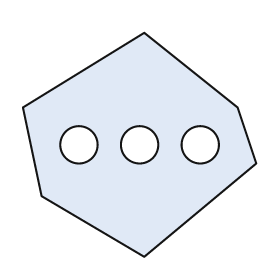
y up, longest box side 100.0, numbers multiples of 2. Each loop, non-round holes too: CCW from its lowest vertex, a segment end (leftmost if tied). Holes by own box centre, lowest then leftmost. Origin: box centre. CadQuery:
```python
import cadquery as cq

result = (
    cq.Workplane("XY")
    .moveTo(2.0, -48.0)
    .lineTo(50.0, -8.0)
    .lineTo(42.0, 16.0)
    .lineTo(2.0, 48.0)
    .lineTo(-50.0, 16.0)
    .lineTo(-42.0, -22.0)
    .close()
    .moveTo(-26.0, 0.0)
    .circle(8.0)
    .moveTo(0.0, 0.0)
    .circle(8.0)
    .moveTo(26.0, 0.0)
    .circle(8.0)
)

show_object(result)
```